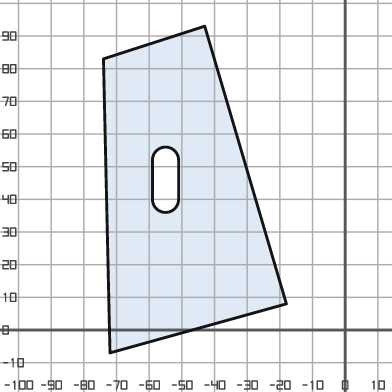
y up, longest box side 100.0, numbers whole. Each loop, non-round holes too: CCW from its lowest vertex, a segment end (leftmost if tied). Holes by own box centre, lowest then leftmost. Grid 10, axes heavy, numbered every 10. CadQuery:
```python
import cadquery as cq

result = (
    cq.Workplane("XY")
    .moveTo(-72.0, -7.0)
    .lineTo(-18.0, 8.0)
    .lineTo(-43.0, 93.0)
    .lineTo(-74.0, 83.0)
    .close()
    .moveTo(-59.0, 40.0)
    .threePointArc((-55.0, 36.0), (-51.0, 40.0))
    .lineTo(-51.0, 52.0)
    .threePointArc((-55.0, 56.0), (-59.0, 52.0))
    .close()
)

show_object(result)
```